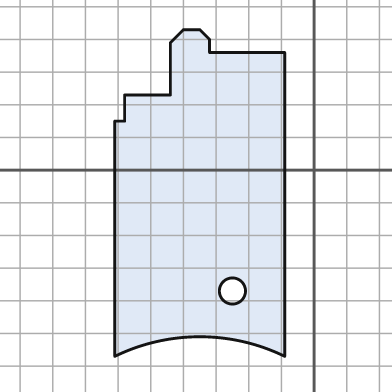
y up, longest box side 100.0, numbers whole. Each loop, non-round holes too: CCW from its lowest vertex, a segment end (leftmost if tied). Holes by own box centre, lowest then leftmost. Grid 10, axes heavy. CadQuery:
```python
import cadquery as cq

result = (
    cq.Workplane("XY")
    .moveTo(-61.0, -57.0)
    .threePointArc((-35.0, -51.0), (-9.0, -57.0))
    .lineTo(-9.0, 36.0)
    .lineTo(-32.0, 36.0)
    .lineTo(-32.0, 40.0)
    .lineTo(-35.0, 43.0)
    .lineTo(-40.0, 43.0)
    .lineTo(-44.0, 39.0)
    .lineTo(-44.0, 23.0)
    .lineTo(-58.0, 23.0)
    .lineTo(-58.0, 15.0)
    .lineTo(-61.0, 15.0)
    .close()
    .moveTo(-25.0, -37.0)
    .circle(4.0)
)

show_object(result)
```